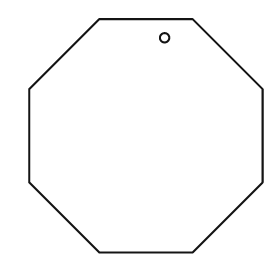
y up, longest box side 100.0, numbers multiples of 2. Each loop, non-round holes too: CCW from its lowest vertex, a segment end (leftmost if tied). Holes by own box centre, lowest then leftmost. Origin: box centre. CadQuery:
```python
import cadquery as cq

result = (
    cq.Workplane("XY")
    .moveTo(-20.0, -50.0)
    .lineTo(20.0, -50.0)
    .lineTo(50.0, -20.0)
    .lineTo(50.0, 20.0)
    .lineTo(20.0, 50.0)
    .lineTo(-20.0, 50.0)
    .lineTo(-50.0, 20.0)
    .lineTo(-50.0, -20.0)
    .close()
    .moveTo(8.0, 42.0)
    .circle(2.0)
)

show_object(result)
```